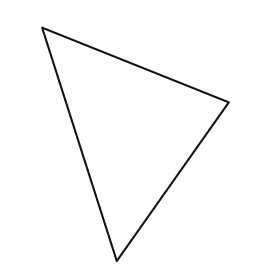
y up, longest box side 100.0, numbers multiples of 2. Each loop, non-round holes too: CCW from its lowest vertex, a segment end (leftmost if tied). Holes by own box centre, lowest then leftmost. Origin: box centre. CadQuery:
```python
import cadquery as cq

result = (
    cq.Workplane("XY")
    .moveTo(-8.0, -50.0)
    .lineTo(40.0, 18.0)
    .lineTo(-40.0, 50.0)
    .close()
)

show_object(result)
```